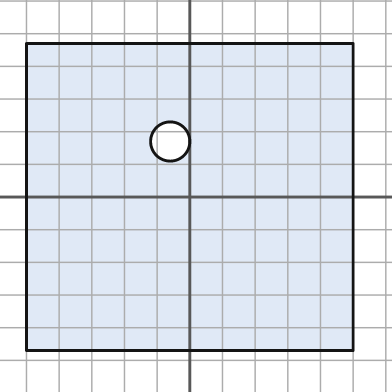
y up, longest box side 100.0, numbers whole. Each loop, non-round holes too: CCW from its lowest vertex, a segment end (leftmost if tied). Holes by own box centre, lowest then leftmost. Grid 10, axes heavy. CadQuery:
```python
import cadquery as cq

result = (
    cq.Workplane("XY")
    .moveTo(-50.0, -47.0)
    .lineTo(50.0, -47.0)
    .lineTo(50.0, 47.0)
    .lineTo(-50.0, 47.0)
    .close()
    .moveTo(-6.0, 17.0)
    .circle(6.0)
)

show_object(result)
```